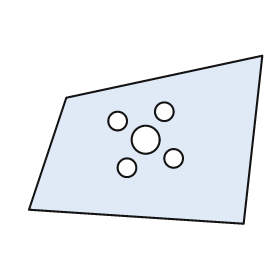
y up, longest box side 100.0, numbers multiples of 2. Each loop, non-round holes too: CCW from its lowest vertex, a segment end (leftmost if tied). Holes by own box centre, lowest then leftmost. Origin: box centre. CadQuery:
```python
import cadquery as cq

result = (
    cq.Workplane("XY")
    .moveTo(42.0, -36.0)
    .lineTo(50.0, 36.0)
    .lineTo(-34.0, 18.0)
    .lineTo(-50.0, -30.0)
    .close()
    .moveTo(-8.0, -12.0)
    .circle(4.0)
    .moveTo(12.0, -8.0)
    .circle(4.0)
    .moveTo(0.0, 0.0)
    .circle(6.0)
    .moveTo(-12.0, 8.0)
    .circle(4.0)
    .moveTo(8.0, 12.0)
    .circle(4.0)
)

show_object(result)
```